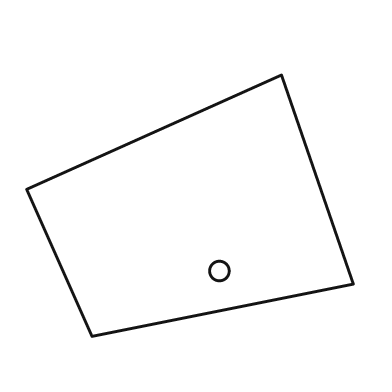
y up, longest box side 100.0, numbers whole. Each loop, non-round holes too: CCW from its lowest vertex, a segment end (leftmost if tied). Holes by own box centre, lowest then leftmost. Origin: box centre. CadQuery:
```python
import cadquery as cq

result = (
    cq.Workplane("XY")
    .moveTo(-30.0, -40.0)
    .lineTo(50.0, -24.0)
    .lineTo(28.0, 40.0)
    .lineTo(-50.0, 5.0)
    .close()
    .moveTo(9.0, -20.0)
    .circle(3.0)
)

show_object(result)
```